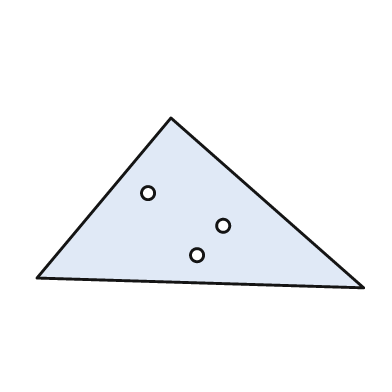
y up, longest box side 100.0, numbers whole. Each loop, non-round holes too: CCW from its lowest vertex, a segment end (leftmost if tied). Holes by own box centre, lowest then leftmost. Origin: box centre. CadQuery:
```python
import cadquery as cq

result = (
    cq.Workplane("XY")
    .moveTo(50.0, -26.0)
    .lineTo(-9.0, 26.0)
    .lineTo(-50.0, -23.0)
    .close()
    .moveTo(-1.0, -16.0)
    .circle(2.0)
    .moveTo(7.0, -7.0)
    .circle(2.0)
    .moveTo(-16.0, 3.0)
    .circle(2.0)
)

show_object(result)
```